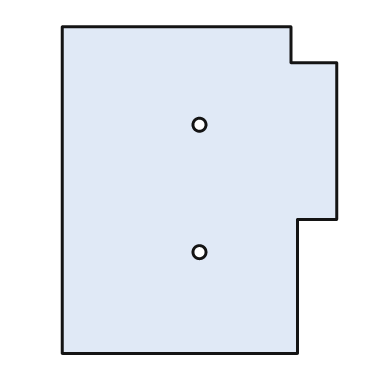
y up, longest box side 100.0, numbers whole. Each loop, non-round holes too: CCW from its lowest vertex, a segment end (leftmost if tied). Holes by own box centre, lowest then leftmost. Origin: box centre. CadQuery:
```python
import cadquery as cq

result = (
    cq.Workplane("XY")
    .moveTo(-42.0, -50.0)
    .lineTo(30.0, -50.0)
    .lineTo(30.0, -9.0)
    .lineTo(42.0, -9.0)
    .lineTo(42.0, 39.0)
    .lineTo(28.0, 39.0)
    .lineTo(28.0, 50.0)
    .lineTo(-42.0, 50.0)
    .close()
    .moveTo(0.0, -19.0)
    .circle(2.0)
    .moveTo(0.0, 20.0)
    .circle(2.0)
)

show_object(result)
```